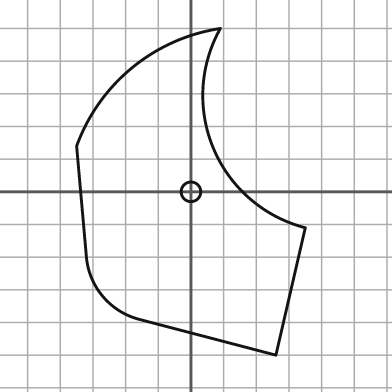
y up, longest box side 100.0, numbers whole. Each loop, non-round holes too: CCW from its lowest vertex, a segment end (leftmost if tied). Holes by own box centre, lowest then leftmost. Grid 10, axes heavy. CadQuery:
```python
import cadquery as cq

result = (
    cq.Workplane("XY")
    .moveTo(26.0, -50.0)
    .lineTo(35.0, -11.0)
    .threePointArc((7.0, 13.0), (9.0, 50.0))
    .threePointArc((-18.0, 38.0), (-35.0, 14.0))
    .lineTo(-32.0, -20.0)
    .threePointArc((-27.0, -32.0), (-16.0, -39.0))
    .close()
    .moveTo(0.0, 0.0)
    .circle(3.0)
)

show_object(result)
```